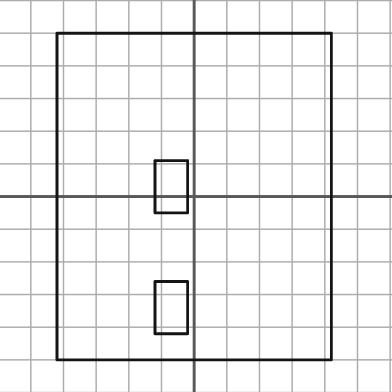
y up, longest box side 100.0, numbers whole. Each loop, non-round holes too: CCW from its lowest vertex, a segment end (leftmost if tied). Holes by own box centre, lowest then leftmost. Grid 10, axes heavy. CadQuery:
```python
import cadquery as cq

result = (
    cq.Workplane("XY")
    .moveTo(-42.0, -50.0)
    .lineTo(42.0, -50.0)
    .lineTo(42.0, 50.0)
    .lineTo(-42.0, 50.0)
    .close()
    .moveTo(-12.0, -42.0)
    .lineTo(-2.0, -42.0)
    .lineTo(-2.0, -26.0)
    .lineTo(-12.0, -26.0)
    .close()
    .moveTo(-12.0, -5.0)
    .lineTo(-2.0, -5.0)
    .lineTo(-2.0, 11.0)
    .lineTo(-12.0, 11.0)
    .close()
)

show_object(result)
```